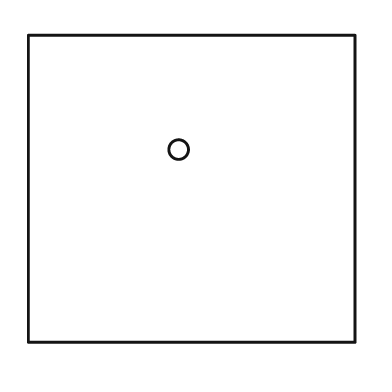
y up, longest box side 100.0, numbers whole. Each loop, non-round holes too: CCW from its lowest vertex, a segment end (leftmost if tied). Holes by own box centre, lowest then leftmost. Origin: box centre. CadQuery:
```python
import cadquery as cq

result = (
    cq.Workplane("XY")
    .moveTo(-50.0, -47.0)
    .lineTo(50.0, -47.0)
    .lineTo(50.0, 47.0)
    .lineTo(-50.0, 47.0)
    .close()
    .moveTo(-4.0, 12.0)
    .circle(3.0)
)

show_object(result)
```